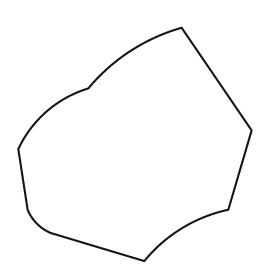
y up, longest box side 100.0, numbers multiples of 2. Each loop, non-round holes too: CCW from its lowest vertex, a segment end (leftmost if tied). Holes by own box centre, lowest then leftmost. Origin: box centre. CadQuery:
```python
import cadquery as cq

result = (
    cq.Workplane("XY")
    .moveTo(4.0, -50.0)
    .threePointArc((20.0, -36.0), (40.0, -28.0))
    .lineTo(50.0, 6.0)
    .lineTo(20.0, 50.0)
    .threePointArc((-2.0, 40.0), (-20.0, 24.0))
    .threePointArc((-38.0, 14.0), (-50.0, -2.0))
    .lineTo(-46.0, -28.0)
    .threePointArc((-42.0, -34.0), (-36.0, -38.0))
    .close()
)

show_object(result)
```